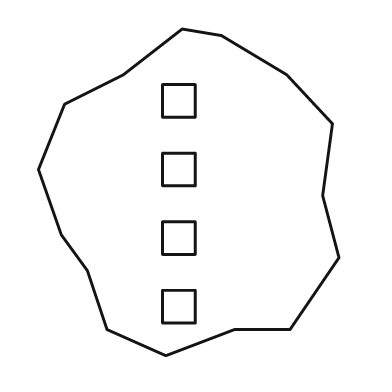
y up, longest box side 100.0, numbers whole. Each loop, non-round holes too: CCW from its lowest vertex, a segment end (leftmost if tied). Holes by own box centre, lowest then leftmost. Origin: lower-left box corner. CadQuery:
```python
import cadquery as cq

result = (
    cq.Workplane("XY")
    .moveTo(39.0, 0.0)
    .lineTo(60.0, 8.0)
    .lineTo(77.0, 8.0)
    .lineTo(92.0, 30.0)
    .lineTo(87.0, 49.0)
    .lineTo(90.0, 71.0)
    .lineTo(76.0, 86.0)
    .lineTo(56.0, 98.0)
    .lineTo(44.0, 100.0)
    .lineTo(26.0, 86.0)
    .lineTo(8.0, 77.0)
    .lineTo(0.0, 57.0)
    .lineTo(7.0, 37.0)
    .lineTo(15.0, 26.0)
    .lineTo(21.0, 8.0)
    .close()
    .moveTo(38.0, 10.0)
    .lineTo(48.0, 10.0)
    .lineTo(48.0, 20.0)
    .lineTo(38.0, 20.0)
    .close()
    .moveTo(38.0, 31.0)
    .lineTo(48.0, 31.0)
    .lineTo(48.0, 41.0)
    .lineTo(38.0, 41.0)
    .close()
    .moveTo(38.0, 52.0)
    .lineTo(48.0, 52.0)
    .lineTo(48.0, 62.0)
    .lineTo(38.0, 62.0)
    .close()
    .moveTo(38.0, 73.0)
    .lineTo(48.0, 73.0)
    .lineTo(48.0, 83.0)
    .lineTo(38.0, 83.0)
    .close()
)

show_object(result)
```